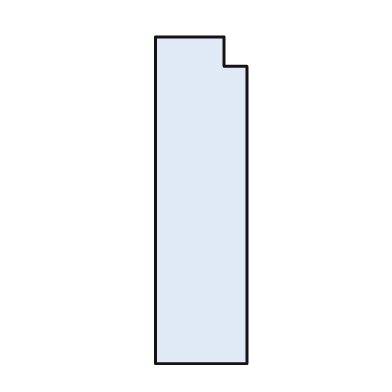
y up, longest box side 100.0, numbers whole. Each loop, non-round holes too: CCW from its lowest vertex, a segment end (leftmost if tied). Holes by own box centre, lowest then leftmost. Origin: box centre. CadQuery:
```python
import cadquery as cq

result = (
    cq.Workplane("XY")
    .moveTo(-14.0, -50.0)
    .lineTo(14.0, -50.0)
    .lineTo(14.0, 41.0)
    .lineTo(7.0, 41.0)
    .lineTo(7.0, 50.0)
    .lineTo(-14.0, 50.0)
    .close()
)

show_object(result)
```